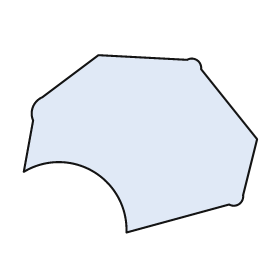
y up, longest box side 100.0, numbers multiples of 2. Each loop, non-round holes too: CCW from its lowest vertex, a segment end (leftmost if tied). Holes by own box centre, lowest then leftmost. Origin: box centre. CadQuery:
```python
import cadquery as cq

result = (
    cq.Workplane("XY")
    .moveTo(-6.0, -38.0)
    .lineTo(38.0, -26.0)
    .threePointArc((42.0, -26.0), (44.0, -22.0))
    .lineTo(50.0, 2.0)
    .lineTo(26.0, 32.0)
    .threePointArc((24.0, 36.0), (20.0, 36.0))
    .lineTo(-18.0, 38.0)
    .lineTo(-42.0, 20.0)
    .threePointArc((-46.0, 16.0), (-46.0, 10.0))
    .lineTo(-50.0, -12.0)
    .threePointArc((-20.0, -12.0), (-6.0, -38.0))
    .close()
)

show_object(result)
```